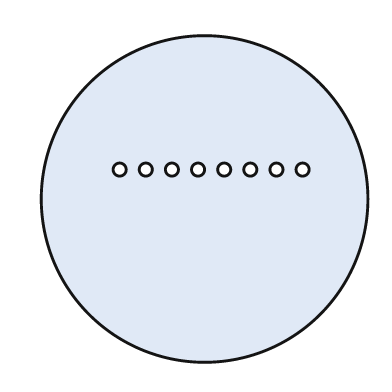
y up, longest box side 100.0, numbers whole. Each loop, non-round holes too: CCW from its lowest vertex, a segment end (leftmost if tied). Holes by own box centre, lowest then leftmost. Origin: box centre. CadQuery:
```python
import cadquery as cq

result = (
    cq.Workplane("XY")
    .moveTo(0.0, 0.0)
    .circle(50.0)
    .moveTo(-26.0, 9.0)
    .circle(2.0)
    .moveTo(-18.0, 9.0)
    .circle(2.0)
    .moveTo(-10.0, 9.0)
    .circle(2.0)
    .moveTo(-2.0, 9.0)
    .circle(2.0)
    .moveTo(6.0, 9.0)
    .circle(2.0)
    .moveTo(14.0, 9.0)
    .circle(2.0)
    .moveTo(22.0, 9.0)
    .circle(2.0)
    .moveTo(30.0, 9.0)
    .circle(2.0)
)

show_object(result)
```